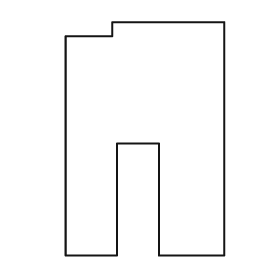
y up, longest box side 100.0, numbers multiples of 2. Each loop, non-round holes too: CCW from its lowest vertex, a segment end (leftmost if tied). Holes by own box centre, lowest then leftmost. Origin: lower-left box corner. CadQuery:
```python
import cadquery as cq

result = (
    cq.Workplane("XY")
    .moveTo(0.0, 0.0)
    .lineTo(22.0, 0.0)
    .lineTo(22.0, 48.0)
    .lineTo(40.0, 48.0)
    .lineTo(40.0, 0.0)
    .lineTo(68.0, 0.0)
    .lineTo(68.0, 100.0)
    .lineTo(20.0, 100.0)
    .lineTo(20.0, 94.0)
    .lineTo(0.0, 94.0)
    .close()
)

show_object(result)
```